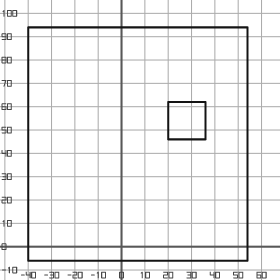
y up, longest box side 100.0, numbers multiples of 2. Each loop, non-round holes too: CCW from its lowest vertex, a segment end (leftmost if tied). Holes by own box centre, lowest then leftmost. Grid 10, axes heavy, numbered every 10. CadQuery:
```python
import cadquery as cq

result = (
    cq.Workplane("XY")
    .moveTo(-40.0, -6.0)
    .lineTo(54.0, -6.0)
    .lineTo(54.0, 94.0)
    .lineTo(-40.0, 94.0)
    .close()
    .moveTo(20.0, 46.0)
    .lineTo(36.0, 46.0)
    .lineTo(36.0, 62.0)
    .lineTo(20.0, 62.0)
    .close()
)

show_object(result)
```